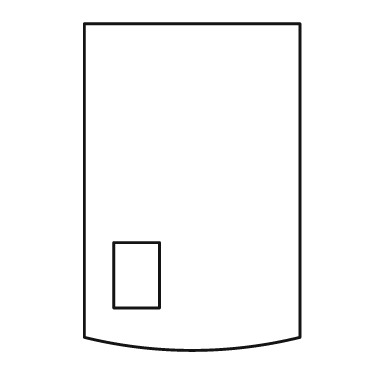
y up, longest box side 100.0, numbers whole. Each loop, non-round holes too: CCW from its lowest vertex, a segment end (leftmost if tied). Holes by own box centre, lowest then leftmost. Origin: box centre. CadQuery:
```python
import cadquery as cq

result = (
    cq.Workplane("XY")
    .moveTo(-33.0, -46.0)
    .threePointArc((0.0, -50.0), (33.0, -46.0))
    .lineTo(33.0, 50.0)
    .lineTo(-33.0, 50.0)
    .close()
    .moveTo(-24.0, -37.0)
    .lineTo(-10.0, -37.0)
    .lineTo(-10.0, -17.0)
    .lineTo(-24.0, -17.0)
    .close()
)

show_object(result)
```